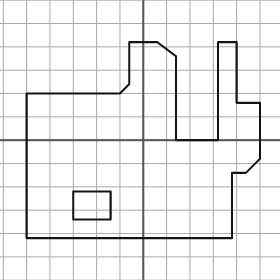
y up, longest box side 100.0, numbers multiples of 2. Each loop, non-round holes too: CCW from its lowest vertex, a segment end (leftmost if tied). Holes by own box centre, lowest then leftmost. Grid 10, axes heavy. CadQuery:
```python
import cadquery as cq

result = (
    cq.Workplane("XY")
    .moveTo(-50.0, -42.0)
    .lineTo(38.0, -42.0)
    .lineTo(38.0, -14.0)
    .lineTo(44.0, -14.0)
    .lineTo(50.0, -8.0)
    .lineTo(50.0, 16.0)
    .lineTo(40.0, 16.0)
    .lineTo(40.0, 42.0)
    .lineTo(32.0, 42.0)
    .lineTo(32.0, 0.0)
    .lineTo(14.0, 0.0)
    .lineTo(14.0, 36.0)
    .lineTo(6.0, 42.0)
    .lineTo(-6.0, 42.0)
    .lineTo(-6.0, 24.0)
    .lineTo(-10.0, 20.0)
    .lineTo(-50.0, 20.0)
    .close()
    .moveTo(-30.0, -34.0)
    .lineTo(-14.0, -34.0)
    .lineTo(-14.0, -22.0)
    .lineTo(-30.0, -22.0)
    .close()
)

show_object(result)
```